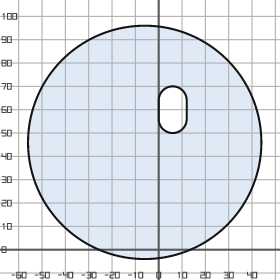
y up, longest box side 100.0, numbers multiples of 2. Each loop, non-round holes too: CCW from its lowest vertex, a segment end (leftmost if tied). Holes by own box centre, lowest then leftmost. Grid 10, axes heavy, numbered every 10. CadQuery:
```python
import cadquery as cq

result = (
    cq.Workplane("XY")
    .moveTo(-6.0, 46.0)
    .circle(50.0)
    .moveTo(0.0, 56.0)
    .threePointArc((6.0, 50.0), (12.0, 56.0))
    .lineTo(12.0, 64.0)
    .threePointArc((6.0, 70.0), (0.0, 64.0))
    .close()
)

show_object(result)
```